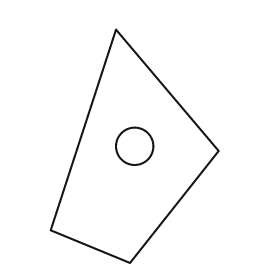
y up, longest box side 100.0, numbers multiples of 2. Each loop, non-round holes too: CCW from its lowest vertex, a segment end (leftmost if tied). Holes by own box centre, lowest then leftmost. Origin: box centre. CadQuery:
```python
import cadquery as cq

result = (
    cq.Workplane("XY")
    .moveTo(-2.0, -50.0)
    .lineTo(36.0, -2.0)
    .lineTo(-8.0, 50.0)
    .lineTo(-36.0, -36.0)
    .close()
    .moveTo(0.0, 0.0)
    .circle(8.0)
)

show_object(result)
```